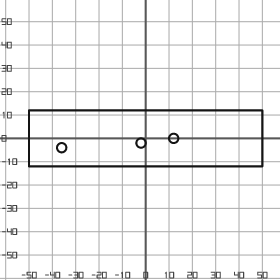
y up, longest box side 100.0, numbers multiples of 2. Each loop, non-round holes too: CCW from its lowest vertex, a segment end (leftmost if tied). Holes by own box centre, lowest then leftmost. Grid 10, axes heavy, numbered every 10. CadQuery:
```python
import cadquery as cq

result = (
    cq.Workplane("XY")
    .moveTo(-50.0, -12.0)
    .lineTo(50.0, -12.0)
    .lineTo(50.0, 12.0)
    .lineTo(-50.0, 12.0)
    .close()
    .moveTo(-36.0, -4.0)
    .circle(2.0)
    .moveTo(-2.0, -2.0)
    .circle(2.0)
    .moveTo(12.0, 0.0)
    .circle(2.0)
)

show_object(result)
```